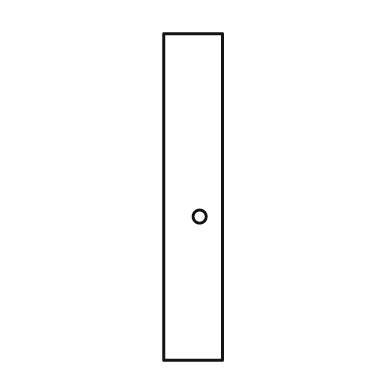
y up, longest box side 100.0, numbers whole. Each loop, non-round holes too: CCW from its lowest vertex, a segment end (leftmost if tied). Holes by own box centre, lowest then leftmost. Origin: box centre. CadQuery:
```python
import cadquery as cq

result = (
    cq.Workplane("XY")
    .moveTo(-9.0, -50.0)
    .lineTo(9.0, -50.0)
    .lineTo(9.0, 50.0)
    .lineTo(-9.0, 50.0)
    .close()
    .moveTo(2.0, -6.0)
    .circle(2.0)
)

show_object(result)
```